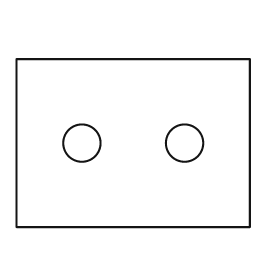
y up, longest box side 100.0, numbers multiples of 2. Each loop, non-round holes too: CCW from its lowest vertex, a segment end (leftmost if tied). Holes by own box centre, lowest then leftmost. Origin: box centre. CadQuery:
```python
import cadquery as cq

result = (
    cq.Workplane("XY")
    .moveTo(-50.0, -36.0)
    .lineTo(50.0, -36.0)
    .lineTo(50.0, 36.0)
    .lineTo(-50.0, 36.0)
    .close()
    .moveTo(-22.0, 0.0)
    .circle(8.0)
    .moveTo(22.0, 0.0)
    .circle(8.0)
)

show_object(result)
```